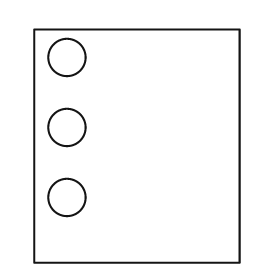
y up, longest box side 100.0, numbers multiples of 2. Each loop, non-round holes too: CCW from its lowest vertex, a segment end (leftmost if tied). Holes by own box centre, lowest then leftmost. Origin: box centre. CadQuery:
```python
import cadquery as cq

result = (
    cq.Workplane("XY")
    .moveTo(-44.0, -50.0)
    .lineTo(44.0, -50.0)
    .lineTo(44.0, 50.0)
    .lineTo(-44.0, 50.0)
    .close()
    .moveTo(-30.0, -22.0)
    .circle(8.0)
    .moveTo(-30.0, 8.0)
    .circle(8.0)
    .moveTo(-30.0, 38.0)
    .circle(8.0)
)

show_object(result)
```